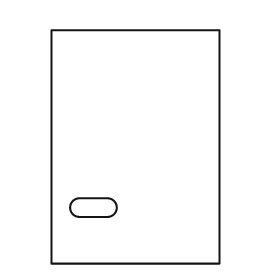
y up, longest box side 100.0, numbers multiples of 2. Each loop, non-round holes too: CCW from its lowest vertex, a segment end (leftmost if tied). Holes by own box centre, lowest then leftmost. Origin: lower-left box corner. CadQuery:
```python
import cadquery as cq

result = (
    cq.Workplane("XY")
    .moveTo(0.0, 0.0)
    .lineTo(72.0, 0.0)
    .lineTo(72.0, 100.0)
    .lineTo(0.0, 100.0)
    .close()
    .moveTo(12.0, 20.0)
    .lineTo(24.0, 20.0)
    .threePointArc((28.0, 24.0), (24.0, 28.0))
    .lineTo(12.0, 28.0)
    .threePointArc((8.0, 24.0), (12.0, 20.0))
    .close()
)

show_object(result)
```